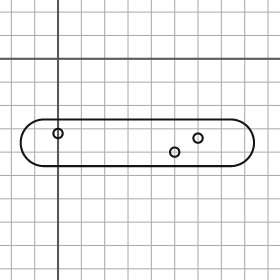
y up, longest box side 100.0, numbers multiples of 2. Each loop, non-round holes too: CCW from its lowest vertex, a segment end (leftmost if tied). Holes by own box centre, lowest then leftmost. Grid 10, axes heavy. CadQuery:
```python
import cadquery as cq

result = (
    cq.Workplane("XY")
    .moveTo(-6.0, -46.0)
    .lineTo(74.0, -46.0)
    .threePointArc((84.0, -36.0), (74.0, -26.0))
    .lineTo(-6.0, -26.0)
    .threePointArc((-16.0, -36.0), (-6.0, -46.0))
    .close()
    .moveTo(50.0, -40.0)
    .circle(2.0)
    .moveTo(60.0, -34.0)
    .circle(2.0)
    .moveTo(0.0, -32.0)
    .circle(2.0)
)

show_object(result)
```